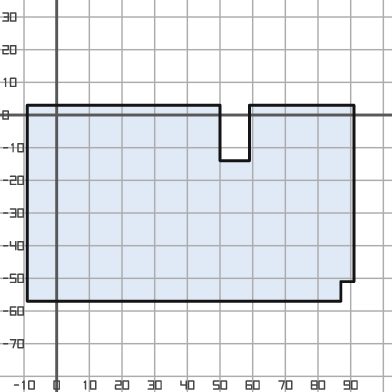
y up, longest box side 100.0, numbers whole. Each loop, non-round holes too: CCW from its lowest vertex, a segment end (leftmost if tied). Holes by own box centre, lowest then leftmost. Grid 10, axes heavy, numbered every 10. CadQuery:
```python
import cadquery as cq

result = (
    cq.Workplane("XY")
    .moveTo(-9.0, -57.0)
    .lineTo(87.0, -57.0)
    .lineTo(87.0, -51.0)
    .lineTo(91.0, -51.0)
    .lineTo(91.0, 3.0)
    .lineTo(59.0, 3.0)
    .lineTo(59.0, -14.0)
    .lineTo(50.0, -14.0)
    .lineTo(50.0, 3.0)
    .lineTo(-9.0, 3.0)
    .close()
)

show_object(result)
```